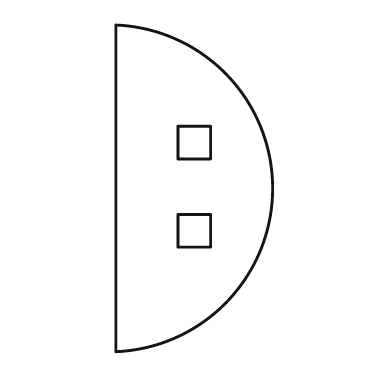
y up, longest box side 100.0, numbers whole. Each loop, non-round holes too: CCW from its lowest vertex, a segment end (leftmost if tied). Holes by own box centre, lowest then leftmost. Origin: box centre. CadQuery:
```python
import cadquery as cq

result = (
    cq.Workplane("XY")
    .moveTo(-24.0, -50.0)
    .threePointArc((24.0, 0.0), (-24.0, 50.0))
    .close()
    .moveTo(-5.0, -18.0)
    .lineTo(5.0, -18.0)
    .lineTo(5.0, -8.0)
    .lineTo(-5.0, -8.0)
    .close()
    .moveTo(-5.0, 9.0)
    .lineTo(5.0, 9.0)
    .lineTo(5.0, 19.0)
    .lineTo(-5.0, 19.0)
    .close()
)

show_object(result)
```